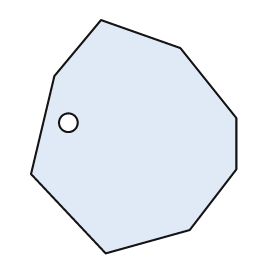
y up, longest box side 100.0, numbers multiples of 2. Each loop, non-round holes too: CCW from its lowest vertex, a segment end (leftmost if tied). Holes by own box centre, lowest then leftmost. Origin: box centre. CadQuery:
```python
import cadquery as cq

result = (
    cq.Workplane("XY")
    .moveTo(-12.0, -50.0)
    .lineTo(24.0, -40.0)
    .lineTo(44.0, -14.0)
    .lineTo(44.0, 8.0)
    .lineTo(20.0, 38.0)
    .lineTo(-14.0, 50.0)
    .lineTo(-34.0, 26.0)
    .lineTo(-44.0, -16.0)
    .close()
    .moveTo(-28.0, 6.0)
    .circle(4.0)
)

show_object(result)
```